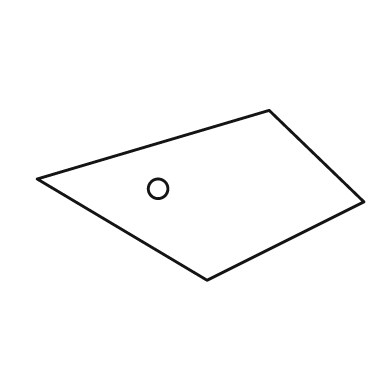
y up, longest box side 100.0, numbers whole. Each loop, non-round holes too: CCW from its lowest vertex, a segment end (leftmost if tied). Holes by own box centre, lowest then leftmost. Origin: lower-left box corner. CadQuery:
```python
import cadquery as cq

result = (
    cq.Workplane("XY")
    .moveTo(52.0, 0.0)
    .lineTo(100.0, 24.0)
    .lineTo(71.0, 52.0)
    .lineTo(0.0, 31.0)
    .close()
    .moveTo(37.0, 28.0)
    .circle(3.0)
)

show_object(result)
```